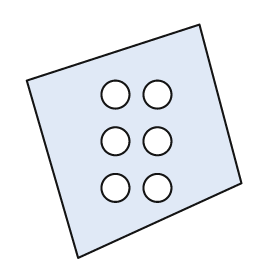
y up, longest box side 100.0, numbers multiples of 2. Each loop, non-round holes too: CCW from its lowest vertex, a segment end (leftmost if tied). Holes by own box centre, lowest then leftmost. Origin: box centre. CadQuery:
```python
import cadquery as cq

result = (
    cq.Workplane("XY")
    .moveTo(-24.0, -50.0)
    .lineTo(46.0, -18.0)
    .lineTo(28.0, 50.0)
    .lineTo(-46.0, 26.0)
    .close()
    .moveTo(-8.0, -20.0)
    .circle(6.0)
    .moveTo(10.0, -20.0)
    .circle(6.0)
    .moveTo(-8.0, 0.0)
    .circle(6.0)
    .moveTo(10.0, 0.0)
    .circle(6.0)
    .moveTo(-8.0, 20.0)
    .circle(6.0)
    .moveTo(10.0, 20.0)
    .circle(6.0)
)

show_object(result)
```